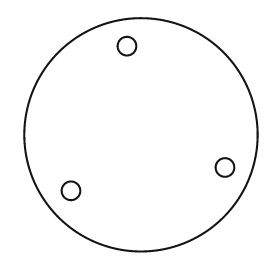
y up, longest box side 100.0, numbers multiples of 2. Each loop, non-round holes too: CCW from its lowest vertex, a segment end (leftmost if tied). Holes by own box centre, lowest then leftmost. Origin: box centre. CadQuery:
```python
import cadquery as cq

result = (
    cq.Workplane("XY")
    .moveTo(0.0, 0.0)
    .circle(50.0)
    .moveTo(-30.0, -24.0)
    .circle(4.0)
    .moveTo(36.0, -14.0)
    .circle(4.0)
    .moveTo(-6.0, 38.0)
    .circle(4.0)
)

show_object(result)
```